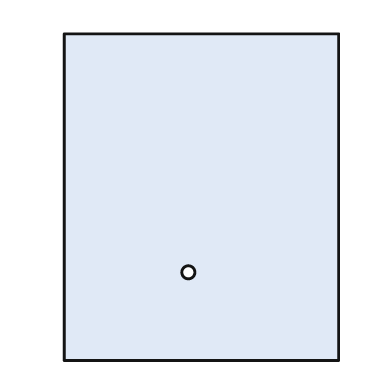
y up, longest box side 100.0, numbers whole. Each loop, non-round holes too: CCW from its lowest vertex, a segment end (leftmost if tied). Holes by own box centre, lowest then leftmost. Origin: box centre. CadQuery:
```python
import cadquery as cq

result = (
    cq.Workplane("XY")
    .moveTo(-42.0, -50.0)
    .lineTo(42.0, -50.0)
    .lineTo(42.0, 50.0)
    .lineTo(-42.0, 50.0)
    .close()
    .moveTo(-4.0, -23.0)
    .circle(2.0)
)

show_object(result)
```